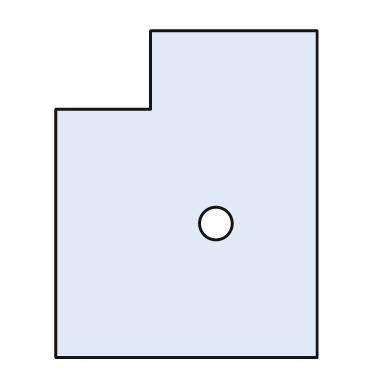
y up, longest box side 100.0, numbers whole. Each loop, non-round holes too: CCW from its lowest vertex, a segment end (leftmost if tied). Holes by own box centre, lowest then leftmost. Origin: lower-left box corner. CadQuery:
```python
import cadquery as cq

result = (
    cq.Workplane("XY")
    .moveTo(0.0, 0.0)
    .lineTo(80.0, 0.0)
    .lineTo(80.0, 100.0)
    .lineTo(29.0, 100.0)
    .lineTo(29.0, 76.0)
    .lineTo(0.0, 76.0)
    .close()
    .moveTo(49.0, 41.0)
    .circle(5.0)
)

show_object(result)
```